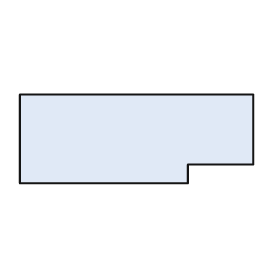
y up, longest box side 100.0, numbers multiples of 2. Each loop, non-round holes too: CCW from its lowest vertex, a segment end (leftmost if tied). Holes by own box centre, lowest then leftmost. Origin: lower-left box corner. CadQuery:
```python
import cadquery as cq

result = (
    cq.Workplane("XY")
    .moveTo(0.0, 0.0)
    .lineTo(72.0, 0.0)
    .lineTo(72.0, 8.0)
    .lineTo(100.0, 8.0)
    .lineTo(100.0, 38.0)
    .lineTo(0.0, 38.0)
    .close()
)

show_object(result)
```